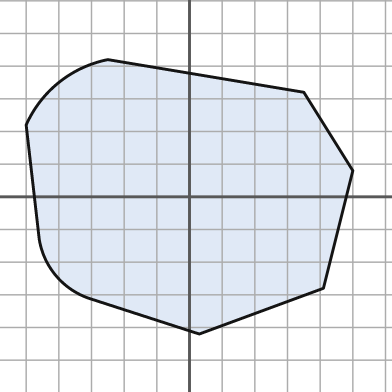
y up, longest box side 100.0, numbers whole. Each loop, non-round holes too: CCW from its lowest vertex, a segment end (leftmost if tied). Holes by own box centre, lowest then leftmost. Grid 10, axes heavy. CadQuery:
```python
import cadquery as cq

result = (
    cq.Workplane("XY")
    .moveTo(3.0, -42.0)
    .lineTo(41.0, -28.0)
    .lineTo(50.0, 8.0)
    .lineTo(35.0, 32.0)
    .lineTo(-25.0, 42.0)
    .threePointArc((-40.0, 35.0), (-50.0, 22.0))
    .lineTo(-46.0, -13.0)
    .threePointArc((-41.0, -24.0), (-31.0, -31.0))
    .close()
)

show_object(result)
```